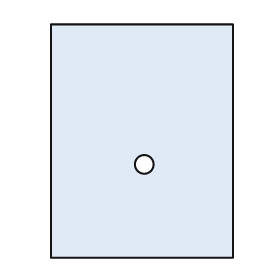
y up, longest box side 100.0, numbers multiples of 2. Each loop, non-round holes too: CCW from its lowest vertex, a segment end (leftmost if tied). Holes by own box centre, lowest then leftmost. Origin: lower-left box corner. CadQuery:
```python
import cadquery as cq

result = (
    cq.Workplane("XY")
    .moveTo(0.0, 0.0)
    .lineTo(78.0, 0.0)
    .lineTo(78.0, 100.0)
    .lineTo(0.0, 100.0)
    .close()
    .moveTo(40.0, 40.0)
    .circle(4.0)
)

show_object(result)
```